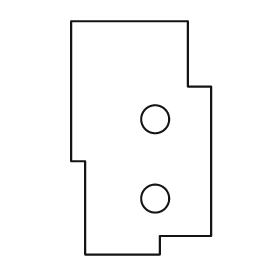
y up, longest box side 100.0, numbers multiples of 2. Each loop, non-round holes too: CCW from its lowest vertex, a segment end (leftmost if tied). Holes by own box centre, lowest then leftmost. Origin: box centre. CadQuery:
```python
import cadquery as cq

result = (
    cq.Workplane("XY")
    .moveTo(-24.0, -50.0)
    .lineTo(8.0, -50.0)
    .lineTo(8.0, -42.0)
    .lineTo(30.0, -42.0)
    .lineTo(30.0, 22.0)
    .lineTo(20.0, 22.0)
    .lineTo(20.0, 50.0)
    .lineTo(-30.0, 50.0)
    .lineTo(-30.0, -10.0)
    .lineTo(-24.0, -10.0)
    .close()
    .moveTo(6.0, -26.0)
    .circle(6.0)
    .moveTo(6.0, 8.0)
    .circle(6.0)
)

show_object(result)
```